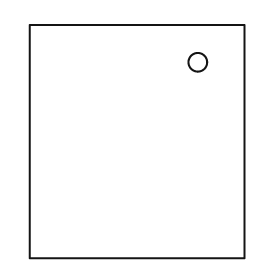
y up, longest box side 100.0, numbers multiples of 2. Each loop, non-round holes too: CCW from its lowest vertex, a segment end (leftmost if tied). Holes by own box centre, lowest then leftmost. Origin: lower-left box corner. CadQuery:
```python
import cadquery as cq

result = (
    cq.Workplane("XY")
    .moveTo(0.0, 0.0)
    .lineTo(92.0, 0.0)
    .lineTo(92.0, 100.0)
    .lineTo(0.0, 100.0)
    .close()
    .moveTo(72.0, 84.0)
    .circle(4.0)
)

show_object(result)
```